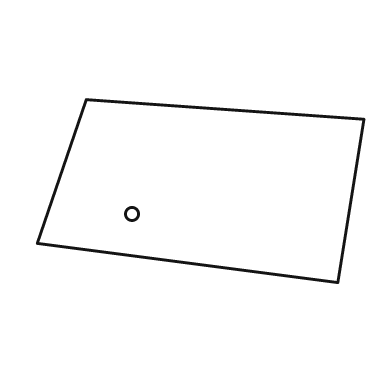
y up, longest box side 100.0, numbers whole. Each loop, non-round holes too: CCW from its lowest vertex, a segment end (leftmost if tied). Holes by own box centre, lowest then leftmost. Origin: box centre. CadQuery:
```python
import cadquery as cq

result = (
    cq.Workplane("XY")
    .moveTo(42.0, -28.0)
    .lineTo(50.0, 22.0)
    .lineTo(-35.0, 28.0)
    .lineTo(-50.0, -16.0)
    .close()
    .moveTo(-21.0, -7.0)
    .circle(2.0)
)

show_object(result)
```